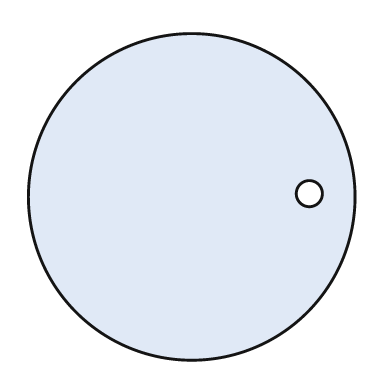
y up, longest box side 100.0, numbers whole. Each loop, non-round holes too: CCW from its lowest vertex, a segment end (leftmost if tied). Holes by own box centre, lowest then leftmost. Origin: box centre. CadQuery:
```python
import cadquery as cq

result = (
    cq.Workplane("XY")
    .moveTo(0.0, 0.0)
    .circle(50.0)
    .moveTo(36.0, 1.0)
    .circle(4.0)
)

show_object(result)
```